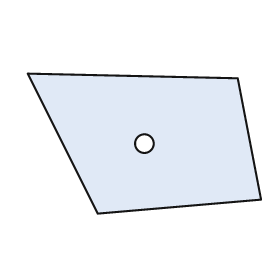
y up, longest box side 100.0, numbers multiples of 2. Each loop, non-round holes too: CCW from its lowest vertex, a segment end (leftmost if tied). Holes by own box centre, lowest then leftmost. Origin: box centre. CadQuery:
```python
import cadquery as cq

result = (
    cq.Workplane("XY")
    .moveTo(-20.0, -30.0)
    .lineTo(50.0, -24.0)
    .lineTo(40.0, 28.0)
    .lineTo(-50.0, 30.0)
    .close()
    .moveTo(0.0, 0.0)
    .circle(4.0)
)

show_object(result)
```